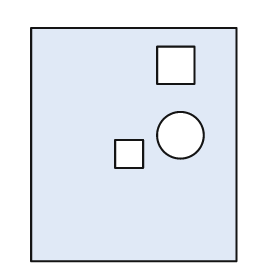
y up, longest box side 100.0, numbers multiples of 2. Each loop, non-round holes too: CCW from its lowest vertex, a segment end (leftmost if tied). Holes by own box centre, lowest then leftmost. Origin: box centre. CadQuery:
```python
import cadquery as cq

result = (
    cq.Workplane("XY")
    .moveTo(-44.0, -50.0)
    .lineTo(44.0, -50.0)
    .lineTo(44.0, 50.0)
    .lineTo(-44.0, 50.0)
    .close()
    .moveTo(-8.0, -10.0)
    .lineTo(4.0, -10.0)
    .lineTo(4.0, 2.0)
    .lineTo(-8.0, 2.0)
    .close()
    .moveTo(20.0, 4.0)
    .circle(10.0)
    .moveTo(10.0, 26.0)
    .lineTo(26.0, 26.0)
    .lineTo(26.0, 42.0)
    .lineTo(10.0, 42.0)
    .close()
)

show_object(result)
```